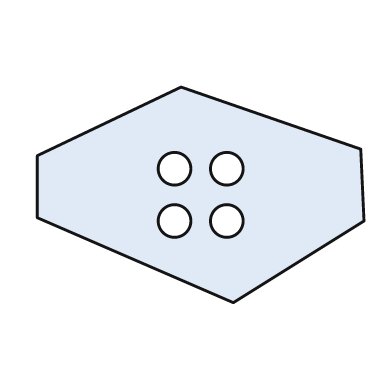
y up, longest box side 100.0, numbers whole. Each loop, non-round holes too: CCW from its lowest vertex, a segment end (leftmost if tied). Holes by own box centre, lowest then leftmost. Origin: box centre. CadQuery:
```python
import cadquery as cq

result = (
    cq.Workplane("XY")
    .moveTo(10.0, -33.0)
    .lineTo(50.0, -8.0)
    .lineTo(49.0, 14.0)
    .lineTo(-6.0, 33.0)
    .lineTo(-50.0, 12.0)
    .lineTo(-50.0, -7.0)
    .close()
    .moveTo(-8.0, -8.0)
    .circle(5.0)
    .moveTo(8.0, -8.0)
    .circle(5.0)
    .moveTo(-8.0, 8.0)
    .circle(5.0)
    .moveTo(8.0, 8.0)
    .circle(5.0)
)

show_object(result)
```